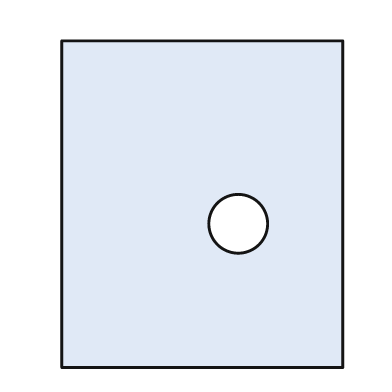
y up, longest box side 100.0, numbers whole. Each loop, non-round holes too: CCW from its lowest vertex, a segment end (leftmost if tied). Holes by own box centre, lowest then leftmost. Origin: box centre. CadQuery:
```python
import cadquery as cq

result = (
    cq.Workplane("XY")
    .moveTo(-43.0, -50.0)
    .lineTo(43.0, -50.0)
    .lineTo(43.0, 50.0)
    .lineTo(-43.0, 50.0)
    .close()
    .moveTo(11.0, -6.0)
    .circle(9.0)
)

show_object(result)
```